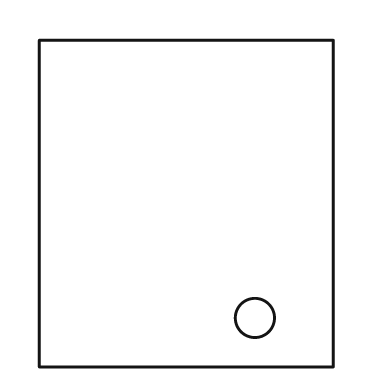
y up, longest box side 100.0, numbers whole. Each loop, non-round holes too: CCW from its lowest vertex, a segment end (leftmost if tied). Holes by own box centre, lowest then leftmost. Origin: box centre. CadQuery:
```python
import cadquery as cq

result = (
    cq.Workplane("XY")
    .moveTo(-45.0, -50.0)
    .lineTo(45.0, -50.0)
    .lineTo(45.0, 50.0)
    .lineTo(-45.0, 50.0)
    .close()
    .moveTo(21.0, -35.0)
    .circle(6.0)
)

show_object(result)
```